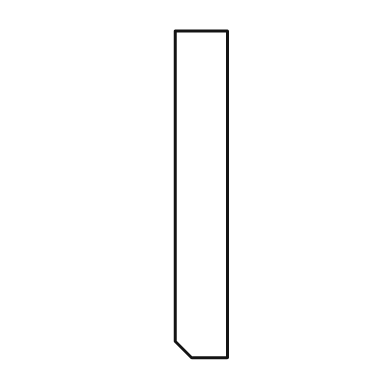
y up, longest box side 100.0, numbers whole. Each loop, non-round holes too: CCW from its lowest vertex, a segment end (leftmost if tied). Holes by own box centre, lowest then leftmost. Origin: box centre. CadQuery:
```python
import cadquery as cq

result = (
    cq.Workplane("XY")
    .moveTo(-3.0, -50.0)
    .lineTo(8.0, -50.0)
    .lineTo(8.0, 50.0)
    .lineTo(-8.0, 50.0)
    .lineTo(-8.0, -45.0)
    .close()
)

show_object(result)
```